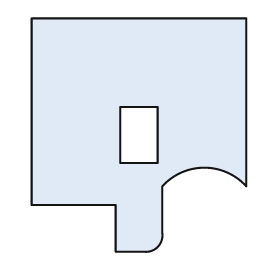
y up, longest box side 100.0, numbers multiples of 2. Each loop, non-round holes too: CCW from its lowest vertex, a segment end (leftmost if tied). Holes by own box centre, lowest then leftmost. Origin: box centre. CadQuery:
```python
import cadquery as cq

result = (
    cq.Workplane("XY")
    .moveTo(-10.0, -50.0)
    .lineTo(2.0, -50.0)
    .threePointArc((8.0, -48.0), (10.0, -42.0))
    .lineTo(10.0, -22.0)
    .threePointArc((28.0, -14.0), (46.0, -22.0))
    .lineTo(46.0, 50.0)
    .lineTo(-46.0, 50.0)
    .lineTo(-46.0, -30.0)
    .lineTo(-10.0, -30.0)
    .close()
    .moveTo(-8.0, -12.0)
    .lineTo(8.0, -12.0)
    .lineTo(8.0, 12.0)
    .lineTo(-8.0, 12.0)
    .close()
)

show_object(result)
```